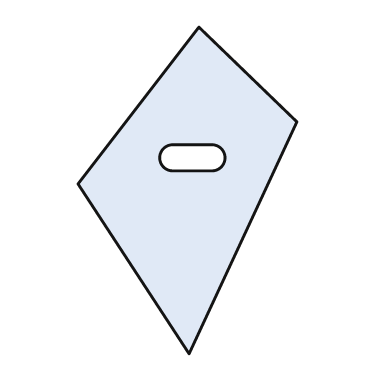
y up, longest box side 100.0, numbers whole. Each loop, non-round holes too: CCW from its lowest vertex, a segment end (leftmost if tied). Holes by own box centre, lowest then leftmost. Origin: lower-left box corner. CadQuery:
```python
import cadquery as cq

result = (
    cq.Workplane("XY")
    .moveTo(34.0, 0.0)
    .lineTo(67.0, 71.0)
    .lineTo(37.0, 100.0)
    .lineTo(0.0, 52.0)
    .close()
    .moveTo(29.0, 56.0)
    .lineTo(41.0, 56.0)
    .threePointArc((45.0, 60.0), (41.0, 64.0))
    .lineTo(29.0, 64.0)
    .threePointArc((25.0, 60.0), (29.0, 56.0))
    .close()
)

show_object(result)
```